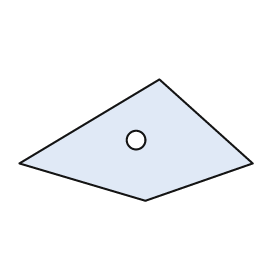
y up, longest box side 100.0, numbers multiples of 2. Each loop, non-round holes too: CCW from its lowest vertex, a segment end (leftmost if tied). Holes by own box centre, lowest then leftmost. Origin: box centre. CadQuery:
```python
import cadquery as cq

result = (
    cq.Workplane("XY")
    .moveTo(4.0, -26.0)
    .lineTo(50.0, -10.0)
    .lineTo(10.0, 26.0)
    .lineTo(-50.0, -10.0)
    .close()
    .moveTo(0.0, 0.0)
    .circle(4.0)
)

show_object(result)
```